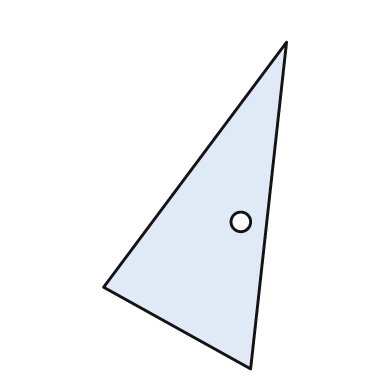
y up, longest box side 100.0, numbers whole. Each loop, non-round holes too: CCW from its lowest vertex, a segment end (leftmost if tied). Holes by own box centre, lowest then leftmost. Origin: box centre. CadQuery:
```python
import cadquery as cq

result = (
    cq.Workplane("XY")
    .moveTo(17.0, -50.0)
    .lineTo(28.0, 50.0)
    .lineTo(-28.0, -25.0)
    .close()
    .moveTo(14.0, -5.0)
    .circle(3.0)
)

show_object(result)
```